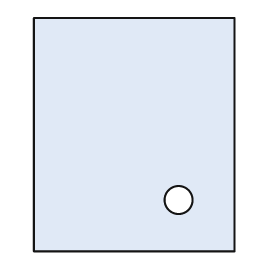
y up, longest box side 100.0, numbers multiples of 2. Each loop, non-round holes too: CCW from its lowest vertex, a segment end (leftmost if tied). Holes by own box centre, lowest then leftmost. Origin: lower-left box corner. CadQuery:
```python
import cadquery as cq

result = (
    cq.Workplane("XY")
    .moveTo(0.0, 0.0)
    .lineTo(86.0, 0.0)
    .lineTo(86.0, 100.0)
    .lineTo(0.0, 100.0)
    .close()
    .moveTo(62.0, 22.0)
    .circle(6.0)
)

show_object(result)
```